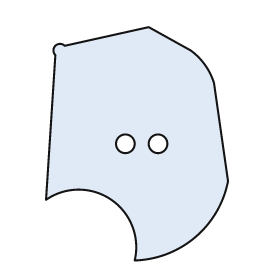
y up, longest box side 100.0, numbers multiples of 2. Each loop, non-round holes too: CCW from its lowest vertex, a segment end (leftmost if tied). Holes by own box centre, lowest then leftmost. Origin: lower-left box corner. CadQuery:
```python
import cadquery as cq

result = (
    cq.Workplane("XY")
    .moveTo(38.0, 0.0)
    .threePointArc((64.0, 10.0), (78.0, 34.0))
    .lineTo(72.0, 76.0)
    .threePointArc((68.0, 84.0), (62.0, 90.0))
    .lineTo(44.0, 100.0)
    .lineTo(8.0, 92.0)
    .threePointArc((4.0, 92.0), (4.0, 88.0))
    .lineTo(0.0, 26.0)
    .threePointArc((28.0, 26.0), (38.0, 0.0))
    .close()
    .moveTo(34.0, 50.0)
    .circle(4.0)
    .moveTo(48.0, 50.0)
    .circle(4.0)
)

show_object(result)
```